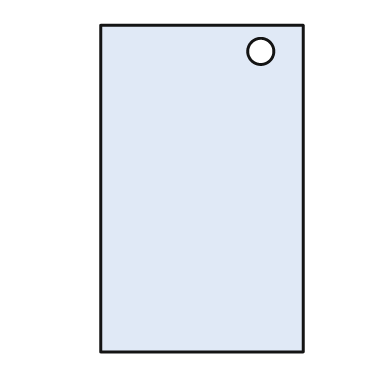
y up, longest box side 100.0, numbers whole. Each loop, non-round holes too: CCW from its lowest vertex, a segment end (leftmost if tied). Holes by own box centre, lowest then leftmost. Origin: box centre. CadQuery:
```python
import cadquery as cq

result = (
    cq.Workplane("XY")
    .moveTo(-31.0, -50.0)
    .lineTo(31.0, -50.0)
    .lineTo(31.0, 50.0)
    .lineTo(-31.0, 50.0)
    .close()
    .moveTo(18.0, 42.0)
    .circle(4.0)
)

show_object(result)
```